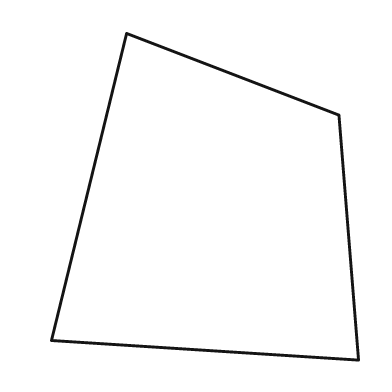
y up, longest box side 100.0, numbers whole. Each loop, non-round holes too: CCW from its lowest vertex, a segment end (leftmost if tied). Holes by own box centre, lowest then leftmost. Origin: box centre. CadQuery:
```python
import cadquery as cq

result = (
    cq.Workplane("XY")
    .moveTo(47.0, -50.0)
    .lineTo(41.0, 25.0)
    .lineTo(-24.0, 50.0)
    .lineTo(-47.0, -44.0)
    .close()
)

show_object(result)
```